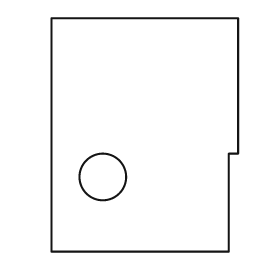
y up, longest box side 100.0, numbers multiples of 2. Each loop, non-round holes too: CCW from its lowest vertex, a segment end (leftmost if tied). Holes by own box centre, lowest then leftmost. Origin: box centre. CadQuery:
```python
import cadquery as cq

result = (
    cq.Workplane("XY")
    .moveTo(-40.0, -50.0)
    .lineTo(36.0, -50.0)
    .lineTo(36.0, -8.0)
    .lineTo(40.0, -8.0)
    .lineTo(40.0, 50.0)
    .lineTo(-40.0, 50.0)
    .close()
    .moveTo(-18.0, -18.0)
    .circle(10.0)
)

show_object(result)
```